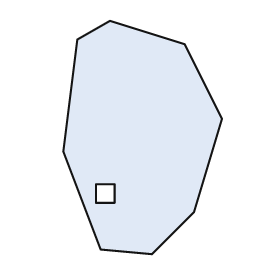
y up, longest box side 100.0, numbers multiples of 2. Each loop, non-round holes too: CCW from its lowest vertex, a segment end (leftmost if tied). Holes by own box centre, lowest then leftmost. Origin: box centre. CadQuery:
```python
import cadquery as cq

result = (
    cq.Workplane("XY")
    .moveTo(4.0, -50.0)
    .lineTo(22.0, -32.0)
    .lineTo(34.0, 8.0)
    .lineTo(18.0, 40.0)
    .lineTo(-14.0, 50.0)
    .lineTo(-28.0, 42.0)
    .lineTo(-34.0, -6.0)
    .lineTo(-18.0, -48.0)
    .close()
    .moveTo(-20.0, -28.0)
    .lineTo(-12.0, -28.0)
    .lineTo(-12.0, -20.0)
    .lineTo(-20.0, -20.0)
    .close()
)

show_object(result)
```